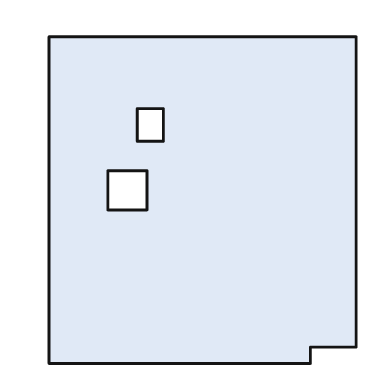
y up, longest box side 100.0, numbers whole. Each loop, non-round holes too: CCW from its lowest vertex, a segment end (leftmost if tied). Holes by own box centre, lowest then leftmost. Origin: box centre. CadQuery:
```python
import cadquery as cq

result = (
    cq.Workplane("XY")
    .moveTo(-47.0, -50.0)
    .lineTo(33.0, -50.0)
    .lineTo(33.0, -45.0)
    .lineTo(47.0, -45.0)
    .lineTo(47.0, 50.0)
    .lineTo(-47.0, 50.0)
    .close()
    .moveTo(-29.0, -3.0)
    .lineTo(-17.0, -3.0)
    .lineTo(-17.0, 9.0)
    .lineTo(-29.0, 9.0)
    .close()
    .moveTo(-20.0, 18.0)
    .lineTo(-12.0, 18.0)
    .lineTo(-12.0, 28.0)
    .lineTo(-20.0, 28.0)
    .close()
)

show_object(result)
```